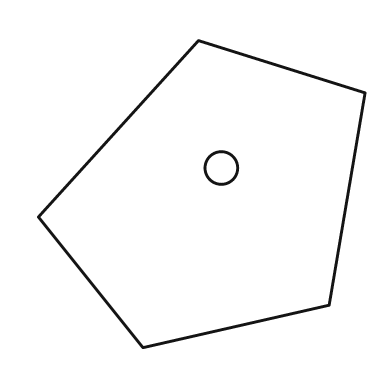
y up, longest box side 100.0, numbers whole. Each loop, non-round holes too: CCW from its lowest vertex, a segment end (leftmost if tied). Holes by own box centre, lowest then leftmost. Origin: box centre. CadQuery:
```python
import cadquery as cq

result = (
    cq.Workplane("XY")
    .moveTo(-18.0, -47.0)
    .lineTo(39.0, -34.0)
    .lineTo(50.0, 31.0)
    .lineTo(-1.0, 47.0)
    .lineTo(-50.0, -7.0)
    .close()
    .moveTo(6.0, 8.0)
    .circle(5.0)
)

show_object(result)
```